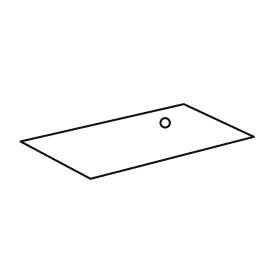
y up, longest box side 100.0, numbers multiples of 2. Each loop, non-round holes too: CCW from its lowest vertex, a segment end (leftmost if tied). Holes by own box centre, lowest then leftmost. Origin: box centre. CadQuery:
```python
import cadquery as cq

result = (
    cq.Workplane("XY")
    .moveTo(-20.0, -16.0)
    .lineTo(50.0, 2.0)
    .lineTo(20.0, 16.0)
    .lineTo(-50.0, 0.0)
    .close()
    .moveTo(12.0, 8.0)
    .circle(2.0)
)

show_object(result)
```